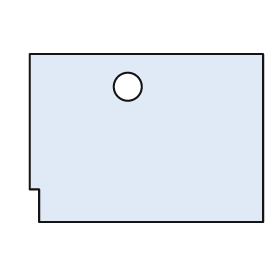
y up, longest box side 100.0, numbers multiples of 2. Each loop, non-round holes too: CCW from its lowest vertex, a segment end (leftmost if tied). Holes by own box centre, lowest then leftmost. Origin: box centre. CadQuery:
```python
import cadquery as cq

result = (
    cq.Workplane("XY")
    .moveTo(-46.0, -36.0)
    .lineTo(50.0, -36.0)
    .lineTo(50.0, 36.0)
    .lineTo(-50.0, 36.0)
    .lineTo(-50.0, -22.0)
    .lineTo(-46.0, -22.0)
    .close()
    .moveTo(-8.0, 22.0)
    .circle(6.0)
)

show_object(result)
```